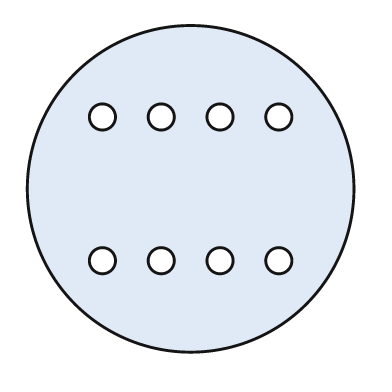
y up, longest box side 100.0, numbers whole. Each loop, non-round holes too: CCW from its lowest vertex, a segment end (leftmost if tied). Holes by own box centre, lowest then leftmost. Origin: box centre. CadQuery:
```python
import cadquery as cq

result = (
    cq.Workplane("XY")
    .moveTo(0.0, 0.0)
    .circle(50.0)
    .moveTo(-27.0, -22.0)
    .circle(4.0)
    .moveTo(-9.0, -22.0)
    .circle(4.0)
    .moveTo(9.0, -22.0)
    .circle(4.0)
    .moveTo(27.0, -22.0)
    .circle(4.0)
    .moveTo(-27.0, 22.0)
    .circle(4.0)
    .moveTo(-9.0, 22.0)
    .circle(4.0)
    .moveTo(9.0, 22.0)
    .circle(4.0)
    .moveTo(27.0, 22.0)
    .circle(4.0)
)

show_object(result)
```